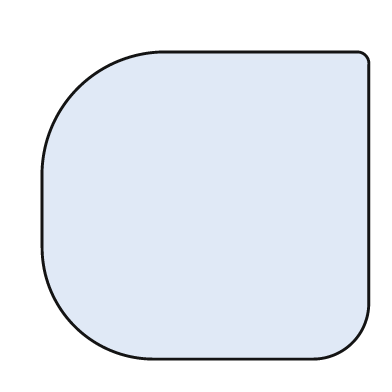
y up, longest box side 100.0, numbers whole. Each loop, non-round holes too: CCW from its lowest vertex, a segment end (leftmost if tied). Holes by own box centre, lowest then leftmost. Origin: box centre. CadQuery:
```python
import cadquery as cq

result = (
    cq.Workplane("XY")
    .moveTo(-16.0, -47.0)
    .lineTo(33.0, -47.0)
    .threePointArc((45.0, -42.0), (50.0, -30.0))
    .lineTo(50.0, 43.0)
    .threePointArc((49.0, 46.0), (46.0, 47.0))
    .lineTo(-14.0, 47.0)
    .threePointArc((-39.0, 36.0), (-50.0, 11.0))
    .lineTo(-50.0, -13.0)
    .threePointArc((-40.0, -37.0), (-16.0, -47.0))
    .close()
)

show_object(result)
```